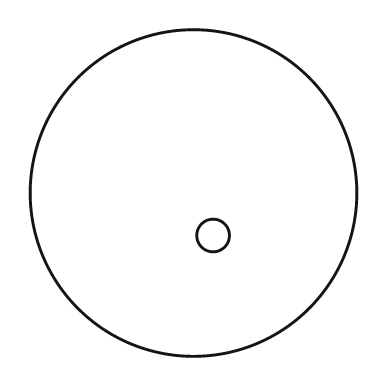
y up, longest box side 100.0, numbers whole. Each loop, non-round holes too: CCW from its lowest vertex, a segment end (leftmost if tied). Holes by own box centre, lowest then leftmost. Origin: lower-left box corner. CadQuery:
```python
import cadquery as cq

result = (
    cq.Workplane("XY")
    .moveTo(50.0, 50.0)
    .circle(50.0)
    .moveTo(56.0, 37.0)
    .circle(5.0)
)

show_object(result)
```